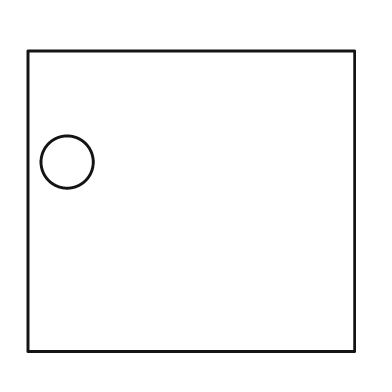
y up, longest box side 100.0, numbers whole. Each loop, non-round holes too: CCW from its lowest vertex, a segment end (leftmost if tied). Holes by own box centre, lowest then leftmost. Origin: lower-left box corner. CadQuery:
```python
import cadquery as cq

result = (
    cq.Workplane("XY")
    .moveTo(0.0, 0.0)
    .lineTo(100.0, 0.0)
    .lineTo(100.0, 92.0)
    .lineTo(0.0, 92.0)
    .close()
    .moveTo(12.0, 58.0)
    .circle(8.0)
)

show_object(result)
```